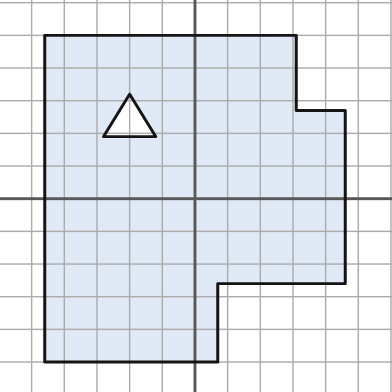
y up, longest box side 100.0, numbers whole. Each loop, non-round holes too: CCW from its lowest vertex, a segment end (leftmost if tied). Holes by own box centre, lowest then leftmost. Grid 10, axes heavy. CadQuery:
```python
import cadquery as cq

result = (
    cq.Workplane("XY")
    .moveTo(-46.0, -50.0)
    .lineTo(7.0, -50.0)
    .lineTo(7.0, -26.0)
    .lineTo(46.0, -26.0)
    .lineTo(46.0, 27.0)
    .lineTo(31.0, 27.0)
    .lineTo(31.0, 50.0)
    .lineTo(-46.0, 50.0)
    .close()
    .moveTo(-28.0, 19.0)
    .lineTo(-12.0, 19.0)
    .lineTo(-20.0, 32.0)
    .close()
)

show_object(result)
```